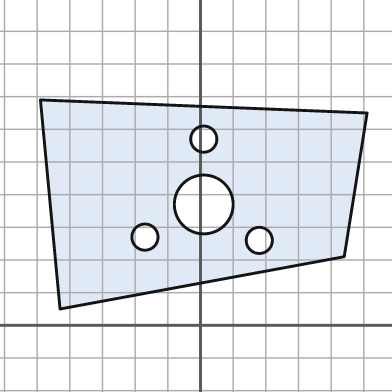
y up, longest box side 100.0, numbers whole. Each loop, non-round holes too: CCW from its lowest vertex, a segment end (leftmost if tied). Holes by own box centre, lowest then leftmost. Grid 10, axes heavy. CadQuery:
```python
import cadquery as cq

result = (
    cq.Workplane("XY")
    .moveTo(-43.0, 5.0)
    .lineTo(44.0, 21.0)
    .lineTo(51.0, 65.0)
    .lineTo(-49.0, 69.0)
    .close()
    .moveTo(18.0, 26.0)
    .circle(4.0)
    .moveTo(-17.0, 27.0)
    .circle(4.0)
    .moveTo(1.0, 37.0)
    .circle(9.0)
    .moveTo(1.0, 57.0)
    .circle(4.0)
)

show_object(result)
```